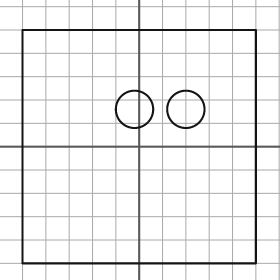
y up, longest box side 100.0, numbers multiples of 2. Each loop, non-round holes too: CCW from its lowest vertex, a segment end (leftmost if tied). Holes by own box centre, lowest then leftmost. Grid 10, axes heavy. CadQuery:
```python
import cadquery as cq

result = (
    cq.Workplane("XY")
    .moveTo(-50.0, -50.0)
    .lineTo(50.0, -50.0)
    .lineTo(50.0, 50.0)
    .lineTo(-50.0, 50.0)
    .close()
    .moveTo(-2.0, 16.0)
    .circle(8.0)
    .moveTo(20.0, 16.0)
    .circle(8.0)
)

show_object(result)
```